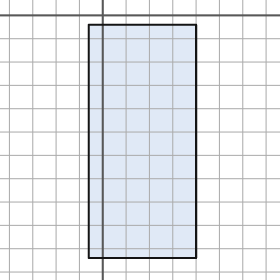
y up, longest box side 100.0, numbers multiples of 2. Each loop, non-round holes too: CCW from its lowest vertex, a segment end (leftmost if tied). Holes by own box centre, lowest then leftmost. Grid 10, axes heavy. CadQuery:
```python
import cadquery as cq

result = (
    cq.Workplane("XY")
    .moveTo(-6.0, -104.0)
    .lineTo(40.0, -104.0)
    .lineTo(40.0, -4.0)
    .lineTo(-6.0, -4.0)
    .close()
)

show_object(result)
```